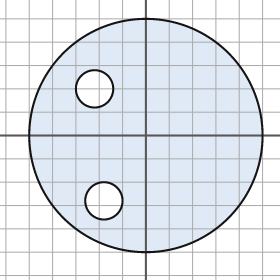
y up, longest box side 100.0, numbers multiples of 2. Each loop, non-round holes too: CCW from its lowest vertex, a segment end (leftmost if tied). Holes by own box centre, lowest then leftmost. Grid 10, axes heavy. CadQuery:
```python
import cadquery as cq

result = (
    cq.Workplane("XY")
    .moveTo(0.0, 0.0)
    .circle(50.0)
    .moveTo(-18.0, -28.0)
    .circle(8.0)
    .moveTo(-22.0, 20.0)
    .circle(8.0)
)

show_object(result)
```